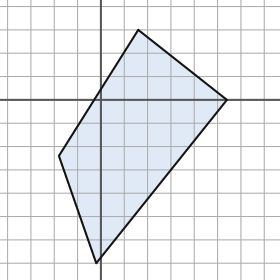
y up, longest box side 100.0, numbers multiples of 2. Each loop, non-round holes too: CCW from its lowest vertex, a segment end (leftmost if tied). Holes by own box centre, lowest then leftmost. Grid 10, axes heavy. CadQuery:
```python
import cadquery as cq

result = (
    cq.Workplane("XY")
    .moveTo(-2.0, -70.0)
    .lineTo(54.0, 0.0)
    .lineTo(16.0, 30.0)
    .lineTo(-18.0, -24.0)
    .close()
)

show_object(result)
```